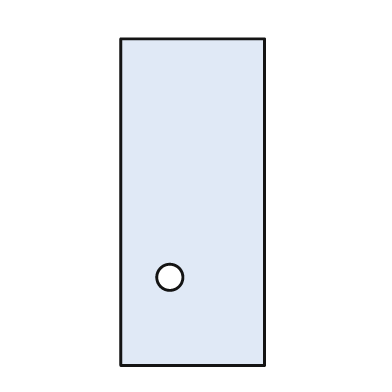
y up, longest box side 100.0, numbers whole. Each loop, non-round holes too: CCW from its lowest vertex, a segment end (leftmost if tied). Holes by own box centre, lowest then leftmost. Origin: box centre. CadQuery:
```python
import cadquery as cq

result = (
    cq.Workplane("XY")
    .moveTo(-22.0, -50.0)
    .lineTo(22.0, -50.0)
    .lineTo(22.0, 50.0)
    .lineTo(-22.0, 50.0)
    .close()
    .moveTo(-7.0, -23.0)
    .circle(4.0)
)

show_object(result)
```